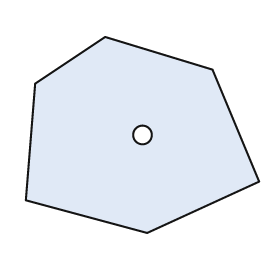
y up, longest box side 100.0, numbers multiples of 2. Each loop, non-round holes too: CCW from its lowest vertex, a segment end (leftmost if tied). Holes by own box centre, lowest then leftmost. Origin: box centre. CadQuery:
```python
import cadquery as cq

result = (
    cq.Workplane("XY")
    .moveTo(2.0, -42.0)
    .lineTo(50.0, -20.0)
    .lineTo(30.0, 28.0)
    .lineTo(-16.0, 42.0)
    .lineTo(-46.0, 22.0)
    .lineTo(-50.0, -28.0)
    .close()
    .moveTo(0.0, 0.0)
    .circle(4.0)
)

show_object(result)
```